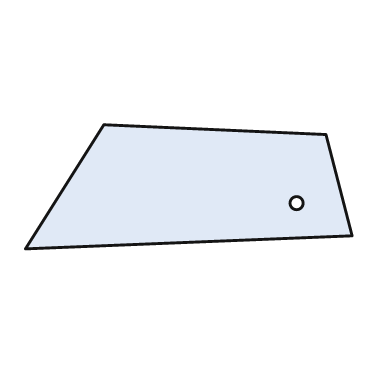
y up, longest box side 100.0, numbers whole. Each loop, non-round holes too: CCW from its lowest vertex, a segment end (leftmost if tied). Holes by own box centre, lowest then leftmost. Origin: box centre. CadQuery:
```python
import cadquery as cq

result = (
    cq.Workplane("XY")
    .moveTo(-50.0, -19.0)
    .lineTo(50.0, -15.0)
    .lineTo(42.0, 16.0)
    .lineTo(-26.0, 19.0)
    .close()
    .moveTo(33.0, -5.0)
    .circle(2.0)
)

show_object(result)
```